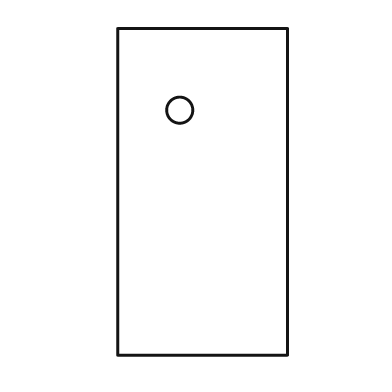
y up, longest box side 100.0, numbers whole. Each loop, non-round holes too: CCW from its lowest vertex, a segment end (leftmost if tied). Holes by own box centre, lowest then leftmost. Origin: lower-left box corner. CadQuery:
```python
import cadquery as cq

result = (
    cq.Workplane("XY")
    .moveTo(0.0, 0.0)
    .lineTo(52.0, 0.0)
    .lineTo(52.0, 100.0)
    .lineTo(0.0, 100.0)
    .close()
    .moveTo(19.0, 75.0)
    .circle(4.0)
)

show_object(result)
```